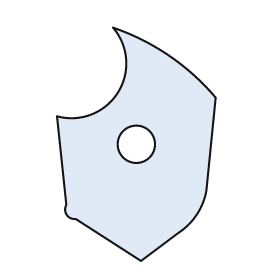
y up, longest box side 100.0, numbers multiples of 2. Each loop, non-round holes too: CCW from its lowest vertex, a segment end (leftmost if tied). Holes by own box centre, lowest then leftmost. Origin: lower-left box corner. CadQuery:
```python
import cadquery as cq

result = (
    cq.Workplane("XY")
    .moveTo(36.0, 0.0)
    .lineTo(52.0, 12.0)
    .threePointArc((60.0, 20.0), (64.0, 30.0))
    .lineTo(68.0, 70.0)
    .threePointArc((48.0, 88.0), (24.0, 100.0))
    .threePointArc((26.0, 72.0), (0.0, 62.0))
    .lineTo(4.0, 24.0)
    .threePointArc((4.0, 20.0), (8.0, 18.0))
    .close()
    .moveTo(34.0, 50.0)
    .circle(8.0)
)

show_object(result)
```